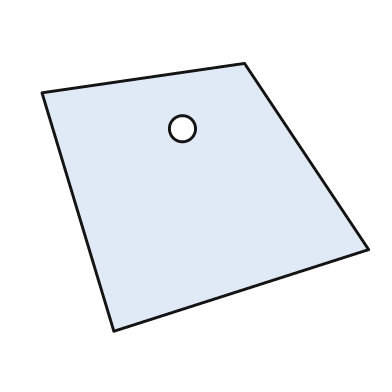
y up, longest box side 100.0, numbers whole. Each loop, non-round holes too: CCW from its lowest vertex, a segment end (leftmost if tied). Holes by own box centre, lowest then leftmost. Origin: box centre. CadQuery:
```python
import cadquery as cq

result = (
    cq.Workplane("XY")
    .moveTo(-28.0, -41.0)
    .lineTo(50.0, -16.0)
    .lineTo(12.0, 41.0)
    .lineTo(-50.0, 32.0)
    .close()
    .moveTo(-7.0, 21.0)
    .circle(4.0)
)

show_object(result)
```